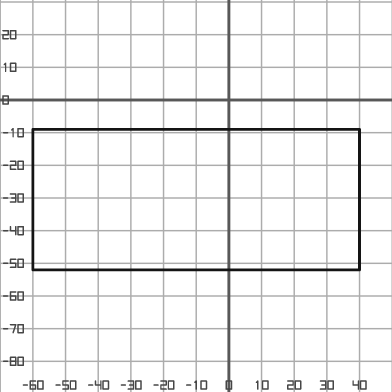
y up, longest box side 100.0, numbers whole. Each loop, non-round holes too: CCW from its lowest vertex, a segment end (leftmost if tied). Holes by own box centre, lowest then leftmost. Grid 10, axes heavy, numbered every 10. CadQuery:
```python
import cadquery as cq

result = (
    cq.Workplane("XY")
    .moveTo(-60.0, -52.0)
    .lineTo(40.0, -52.0)
    .lineTo(40.0, -9.0)
    .lineTo(-60.0, -9.0)
    .close()
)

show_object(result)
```